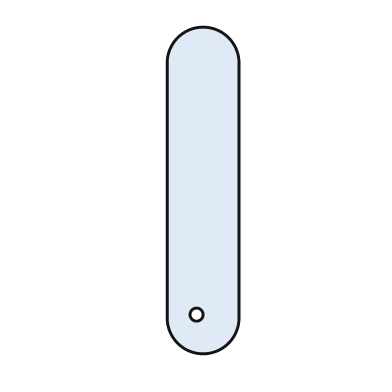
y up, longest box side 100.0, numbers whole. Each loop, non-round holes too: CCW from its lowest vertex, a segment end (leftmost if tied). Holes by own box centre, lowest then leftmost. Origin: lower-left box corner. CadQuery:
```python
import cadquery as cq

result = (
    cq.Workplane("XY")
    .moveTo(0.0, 11.0)
    .threePointArc((11.0, 0.0), (22.0, 11.0))
    .lineTo(22.0, 89.0)
    .threePointArc((11.0, 100.0), (0.0, 89.0))
    .close()
    .moveTo(9.0, 12.0)
    .circle(2.0)
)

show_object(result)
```